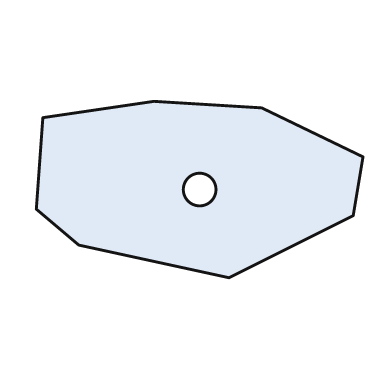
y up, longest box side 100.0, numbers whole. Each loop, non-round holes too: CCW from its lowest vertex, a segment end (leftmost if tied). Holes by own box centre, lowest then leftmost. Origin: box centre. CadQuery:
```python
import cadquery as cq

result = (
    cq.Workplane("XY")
    .moveTo(9.0, -27.0)
    .lineTo(47.0, -8.0)
    .lineTo(50.0, 10.0)
    .lineTo(19.0, 25.0)
    .lineTo(-14.0, 27.0)
    .lineTo(-48.0, 22.0)
    .lineTo(-50.0, -6.0)
    .lineTo(-37.0, -17.0)
    .close()
    .moveTo(0.0, 0.0)
    .circle(5.0)
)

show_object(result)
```